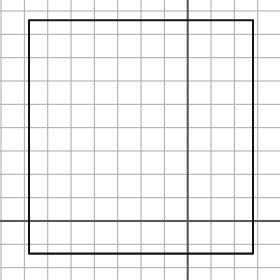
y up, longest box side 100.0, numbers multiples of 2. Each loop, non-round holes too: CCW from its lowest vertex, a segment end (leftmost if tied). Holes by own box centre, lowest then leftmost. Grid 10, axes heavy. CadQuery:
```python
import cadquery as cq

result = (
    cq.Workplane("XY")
    .moveTo(-68.0, -14.0)
    .lineTo(28.0, -14.0)
    .lineTo(28.0, 86.0)
    .lineTo(-68.0, 86.0)
    .close()
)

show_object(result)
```